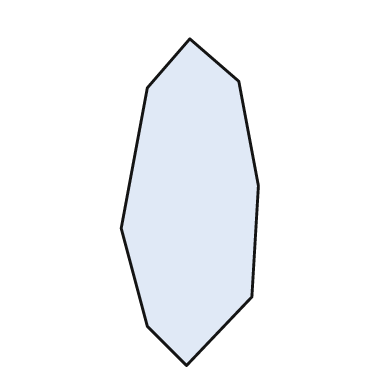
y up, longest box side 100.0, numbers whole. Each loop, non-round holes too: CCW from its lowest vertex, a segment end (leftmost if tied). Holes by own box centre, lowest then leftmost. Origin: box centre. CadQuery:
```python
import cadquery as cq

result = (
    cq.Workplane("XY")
    .moveTo(-1.0, -50.0)
    .lineTo(19.0, -29.0)
    .lineTo(21.0, 5.0)
    .lineTo(15.0, 37.0)
    .lineTo(0.0, 50.0)
    .lineTo(-13.0, 35.0)
    .lineTo(-21.0, -8.0)
    .lineTo(-13.0, -38.0)
    .close()
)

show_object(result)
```